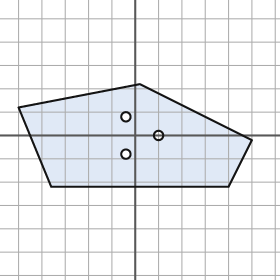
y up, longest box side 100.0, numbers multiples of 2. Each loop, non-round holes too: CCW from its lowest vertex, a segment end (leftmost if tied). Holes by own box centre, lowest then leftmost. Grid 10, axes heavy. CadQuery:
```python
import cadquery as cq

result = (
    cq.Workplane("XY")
    .moveTo(-36.0, -22.0)
    .lineTo(40.0, -22.0)
    .lineTo(50.0, -2.0)
    .lineTo(2.0, 22.0)
    .lineTo(-50.0, 12.0)
    .close()
    .moveTo(-4.0, -8.0)
    .circle(2.0)
    .moveTo(10.0, 0.0)
    .circle(2.0)
    .moveTo(-4.0, 8.0)
    .circle(2.0)
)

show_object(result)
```